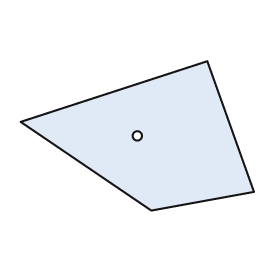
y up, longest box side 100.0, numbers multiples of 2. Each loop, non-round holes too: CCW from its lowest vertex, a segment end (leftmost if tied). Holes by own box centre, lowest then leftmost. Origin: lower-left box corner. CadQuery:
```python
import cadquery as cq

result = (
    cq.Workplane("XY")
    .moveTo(56.0, 0.0)
    .lineTo(100.0, 8.0)
    .lineTo(80.0, 64.0)
    .lineTo(0.0, 38.0)
    .close()
    .moveTo(50.0, 32.0)
    .circle(2.0)
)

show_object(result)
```